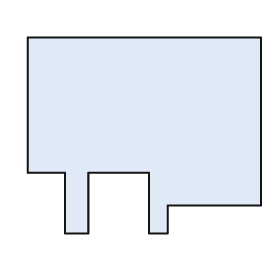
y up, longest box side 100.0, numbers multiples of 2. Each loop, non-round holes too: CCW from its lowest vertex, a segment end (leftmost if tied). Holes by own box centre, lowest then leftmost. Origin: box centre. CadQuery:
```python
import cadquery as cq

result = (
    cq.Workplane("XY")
    .moveTo(-34.0, -42.0)
    .lineTo(-24.0, -42.0)
    .lineTo(-24.0, -16.0)
    .lineTo(2.0, -16.0)
    .lineTo(2.0, -42.0)
    .lineTo(10.0, -42.0)
    .lineTo(10.0, -30.0)
    .lineTo(50.0, -30.0)
    .lineTo(50.0, 42.0)
    .lineTo(-50.0, 42.0)
    .lineTo(-50.0, -16.0)
    .lineTo(-34.0, -16.0)
    .close()
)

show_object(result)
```